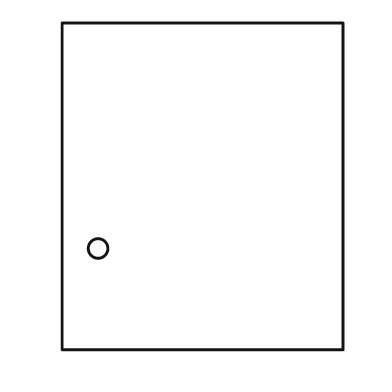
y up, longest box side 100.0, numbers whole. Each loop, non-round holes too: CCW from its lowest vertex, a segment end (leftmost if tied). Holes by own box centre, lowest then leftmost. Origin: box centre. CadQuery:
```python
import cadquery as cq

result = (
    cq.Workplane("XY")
    .moveTo(-43.0, -50.0)
    .lineTo(43.0, -50.0)
    .lineTo(43.0, 50.0)
    .lineTo(-43.0, 50.0)
    .close()
    .moveTo(-32.0, -19.0)
    .circle(3.0)
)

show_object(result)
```